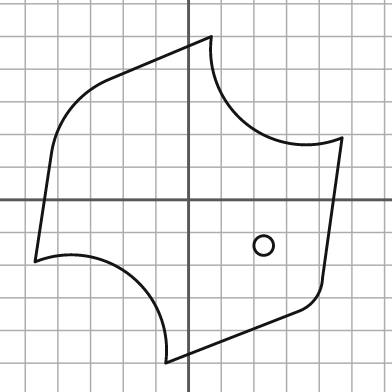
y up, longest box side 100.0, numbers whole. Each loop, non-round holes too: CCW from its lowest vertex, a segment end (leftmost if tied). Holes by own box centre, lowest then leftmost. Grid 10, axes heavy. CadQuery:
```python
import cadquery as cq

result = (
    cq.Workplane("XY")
    .moveTo(-7.0, -50.0)
    .lineTo(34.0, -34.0)
    .threePointArc((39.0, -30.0), (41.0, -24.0))
    .lineTo(47.0, 19.0)
    .threePointArc((18.0, 23.0), (7.0, 50.0))
    .lineTo(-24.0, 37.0)
    .threePointArc((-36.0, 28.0), (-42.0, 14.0))
    .lineTo(-47.0, -19.0)
    .threePointArc((-18.0, -23.0), (-7.0, -50.0))
    .close()
    .moveTo(23.0, -14.0)
    .circle(3.0)
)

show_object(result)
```